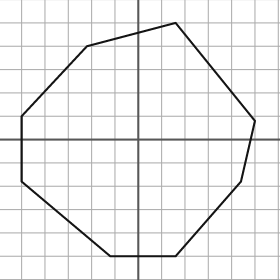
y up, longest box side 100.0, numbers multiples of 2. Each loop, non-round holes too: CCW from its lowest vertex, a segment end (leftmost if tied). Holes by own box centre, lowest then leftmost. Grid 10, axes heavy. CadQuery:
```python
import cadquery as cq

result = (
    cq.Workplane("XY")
    .moveTo(-12.0, -50.0)
    .lineTo(16.0, -50.0)
    .lineTo(44.0, -18.0)
    .lineTo(50.0, 8.0)
    .lineTo(16.0, 50.0)
    .lineTo(-22.0, 40.0)
    .lineTo(-50.0, 10.0)
    .lineTo(-50.0, -18.0)
    .close()
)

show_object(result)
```